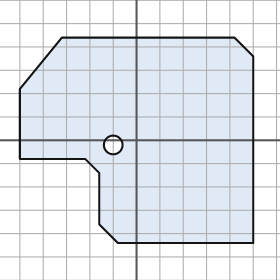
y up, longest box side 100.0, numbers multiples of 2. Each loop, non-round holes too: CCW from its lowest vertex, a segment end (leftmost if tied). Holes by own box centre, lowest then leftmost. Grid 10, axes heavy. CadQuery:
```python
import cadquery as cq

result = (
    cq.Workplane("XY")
    .moveTo(-8.0, -44.0)
    .lineTo(50.0, -44.0)
    .lineTo(50.0, 36.0)
    .lineTo(42.0, 44.0)
    .lineTo(-32.0, 44.0)
    .lineTo(-50.0, 22.0)
    .lineTo(-50.0, -8.0)
    .lineTo(-22.0, -8.0)
    .lineTo(-16.0, -14.0)
    .lineTo(-16.0, -36.0)
    .close()
    .moveTo(-10.0, -2.0)
    .circle(4.0)
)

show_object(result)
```